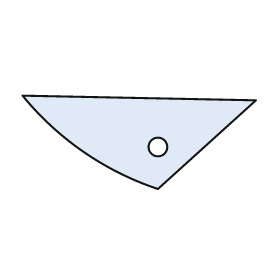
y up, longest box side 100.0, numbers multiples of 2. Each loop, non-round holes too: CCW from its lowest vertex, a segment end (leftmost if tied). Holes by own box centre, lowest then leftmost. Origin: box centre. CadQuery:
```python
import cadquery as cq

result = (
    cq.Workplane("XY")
    .moveTo(8.0, -20.0)
    .lineTo(50.0, 18.0)
    .lineTo(-50.0, 20.0)
    .threePointArc((-24.0, -4.0), (8.0, -20.0))
    .close()
    .moveTo(8.0, -2.0)
    .circle(4.0)
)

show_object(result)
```